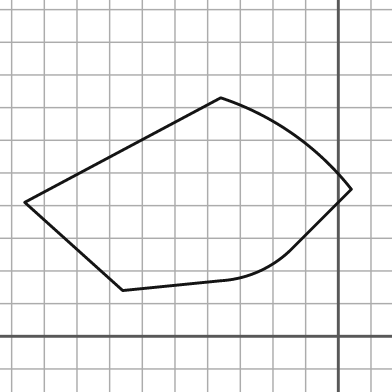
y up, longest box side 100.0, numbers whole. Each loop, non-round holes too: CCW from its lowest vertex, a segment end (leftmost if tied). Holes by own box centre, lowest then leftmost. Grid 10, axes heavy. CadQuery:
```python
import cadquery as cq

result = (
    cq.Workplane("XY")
    .moveTo(-66.0, 14.0)
    .lineTo(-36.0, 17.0)
    .threePointArc((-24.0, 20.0), (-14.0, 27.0))
    .lineTo(4.0, 45.0)
    .threePointArc((-14.0, 62.0), (-36.0, 73.0))
    .lineTo(-96.0, 41.0)
    .close()
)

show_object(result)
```